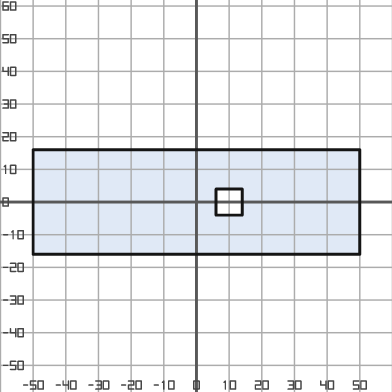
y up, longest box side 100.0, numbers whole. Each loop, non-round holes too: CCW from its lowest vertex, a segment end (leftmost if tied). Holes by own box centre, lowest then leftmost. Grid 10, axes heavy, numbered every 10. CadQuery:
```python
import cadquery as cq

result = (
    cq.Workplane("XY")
    .moveTo(-50.0, -16.0)
    .lineTo(50.0, -16.0)
    .lineTo(50.0, 16.0)
    .lineTo(-50.0, 16.0)
    .close()
    .moveTo(6.0, -4.0)
    .lineTo(14.0, -4.0)
    .lineTo(14.0, 4.0)
    .lineTo(6.0, 4.0)
    .close()
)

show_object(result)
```